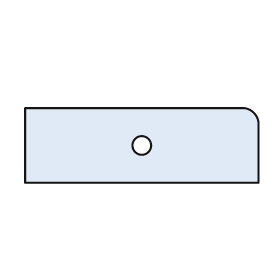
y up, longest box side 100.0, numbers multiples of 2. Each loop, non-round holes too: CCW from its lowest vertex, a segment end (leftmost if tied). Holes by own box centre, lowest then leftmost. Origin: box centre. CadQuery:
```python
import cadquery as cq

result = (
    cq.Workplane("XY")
    .moveTo(-50.0, -16.0)
    .lineTo(50.0, -16.0)
    .lineTo(50.0, 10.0)
    .threePointArc((48.0, 14.0), (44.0, 16.0))
    .lineTo(-50.0, 16.0)
    .close()
    .moveTo(0.0, 0.0)
    .circle(4.0)
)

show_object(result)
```